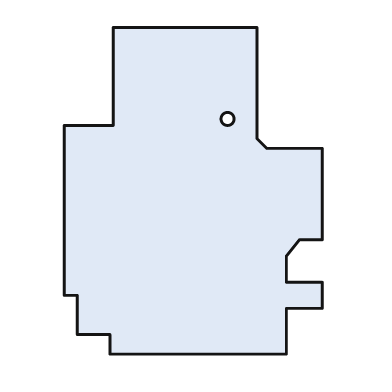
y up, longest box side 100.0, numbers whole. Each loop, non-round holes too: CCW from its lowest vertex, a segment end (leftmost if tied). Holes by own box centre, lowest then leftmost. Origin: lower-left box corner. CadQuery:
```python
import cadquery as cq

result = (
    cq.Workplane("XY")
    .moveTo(14.0, 0.0)
    .lineTo(68.0, 0.0)
    .lineTo(68.0, 14.0)
    .lineTo(79.0, 14.0)
    .lineTo(79.0, 22.0)
    .lineTo(68.0, 22.0)
    .lineTo(68.0, 30.0)
    .lineTo(72.0, 35.0)
    .lineTo(79.0, 35.0)
    .lineTo(79.0, 63.0)
    .lineTo(62.0, 63.0)
    .lineTo(59.0, 66.0)
    .lineTo(59.0, 100.0)
    .lineTo(15.0, 100.0)
    .lineTo(15.0, 70.0)
    .lineTo(0.0, 70.0)
    .lineTo(0.0, 18.0)
    .lineTo(4.0, 18.0)
    .lineTo(4.0, 6.0)
    .lineTo(14.0, 6.0)
    .close()
    .moveTo(50.0, 72.0)
    .circle(2.0)
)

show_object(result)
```